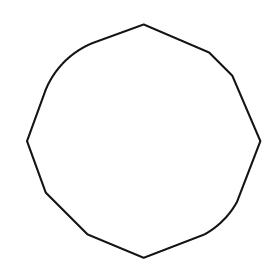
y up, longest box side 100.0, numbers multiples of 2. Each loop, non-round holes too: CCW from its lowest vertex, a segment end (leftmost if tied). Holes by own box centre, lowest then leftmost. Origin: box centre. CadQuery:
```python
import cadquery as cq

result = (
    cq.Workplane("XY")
    .moveTo(0.0, -50.0)
    .lineTo(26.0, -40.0)
    .threePointArc((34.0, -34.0), (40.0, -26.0))
    .lineTo(50.0, 0.0)
    .lineTo(38.0, 28.0)
    .lineTo(28.0, 38.0)
    .lineTo(0.0, 50.0)
    .lineTo(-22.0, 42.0)
    .threePointArc((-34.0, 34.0), (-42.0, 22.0))
    .lineTo(-50.0, 0.0)
    .lineTo(-42.0, -22.0)
    .lineTo(-24.0, -40.0)
    .close()
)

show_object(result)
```